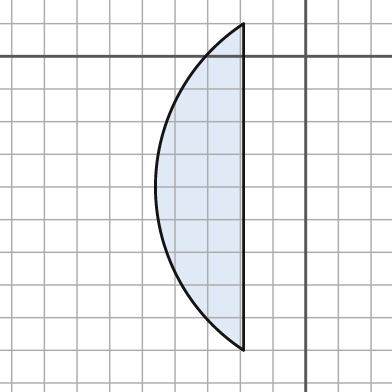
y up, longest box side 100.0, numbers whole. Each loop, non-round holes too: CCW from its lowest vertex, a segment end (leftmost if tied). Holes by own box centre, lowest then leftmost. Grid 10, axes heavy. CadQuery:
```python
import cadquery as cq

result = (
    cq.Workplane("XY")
    .moveTo(-19.0, -90.0)
    .lineTo(-19.0, 10.0)
    .threePointArc((-46.0, -40.0), (-19.0, -90.0))
    .close()
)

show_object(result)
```